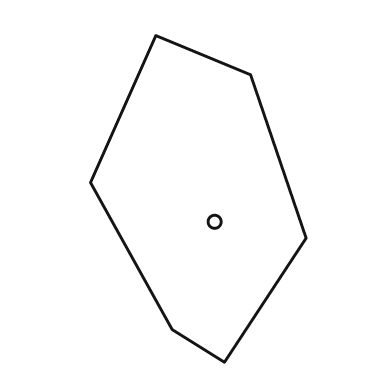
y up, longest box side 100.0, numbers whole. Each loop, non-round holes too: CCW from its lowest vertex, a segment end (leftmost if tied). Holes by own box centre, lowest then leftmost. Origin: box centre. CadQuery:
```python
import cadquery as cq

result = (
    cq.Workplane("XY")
    .moveTo(8.0, -50.0)
    .lineTo(33.0, -12.0)
    .lineTo(16.0, 38.0)
    .lineTo(-13.0, 50.0)
    .lineTo(-33.0, 5.0)
    .lineTo(-8.0, -40.0)
    .close()
    .moveTo(5.0, -7.0)
    .circle(2.0)
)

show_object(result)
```